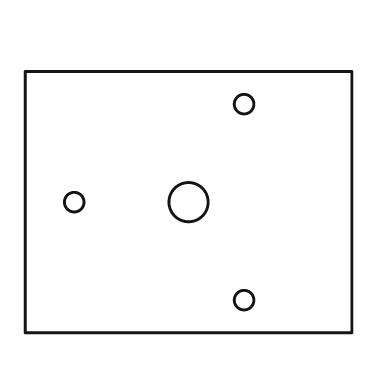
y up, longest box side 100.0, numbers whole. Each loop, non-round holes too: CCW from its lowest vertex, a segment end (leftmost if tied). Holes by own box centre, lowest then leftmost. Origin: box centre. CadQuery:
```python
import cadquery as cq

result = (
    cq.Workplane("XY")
    .moveTo(-50.0, -40.0)
    .lineTo(50.0, -40.0)
    .lineTo(50.0, 40.0)
    .lineTo(-50.0, 40.0)
    .close()
    .moveTo(17.0, -30.0)
    .circle(3.0)
    .moveTo(-35.0, 0.0)
    .circle(3.0)
    .moveTo(0.0, 0.0)
    .circle(6.0)
    .moveTo(17.0, 30.0)
    .circle(3.0)
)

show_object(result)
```